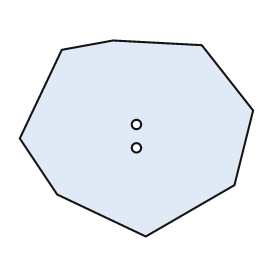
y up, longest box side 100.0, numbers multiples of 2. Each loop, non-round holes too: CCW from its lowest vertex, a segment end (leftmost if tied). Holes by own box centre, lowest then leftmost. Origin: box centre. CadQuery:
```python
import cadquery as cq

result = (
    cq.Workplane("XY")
    .moveTo(4.0, -42.0)
    .lineTo(42.0, -20.0)
    .lineTo(50.0, 12.0)
    .lineTo(28.0, 40.0)
    .lineTo(-10.0, 42.0)
    .lineTo(-32.0, 38.0)
    .lineTo(-50.0, 0.0)
    .lineTo(-34.0, -24.0)
    .close()
    .moveTo(0.0, -4.0)
    .circle(2.0)
    .moveTo(0.0, 6.0)
    .circle(2.0)
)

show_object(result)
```